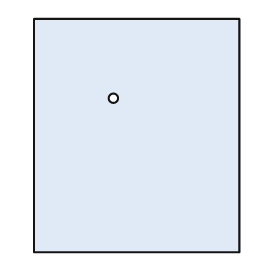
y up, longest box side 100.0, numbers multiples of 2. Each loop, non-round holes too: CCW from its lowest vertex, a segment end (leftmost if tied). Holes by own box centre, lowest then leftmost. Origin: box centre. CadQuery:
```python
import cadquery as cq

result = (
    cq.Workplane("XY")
    .moveTo(-44.0, -50.0)
    .lineTo(44.0, -50.0)
    .lineTo(44.0, 50.0)
    .lineTo(-44.0, 50.0)
    .close()
    .moveTo(-10.0, 16.0)
    .circle(2.0)
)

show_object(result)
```